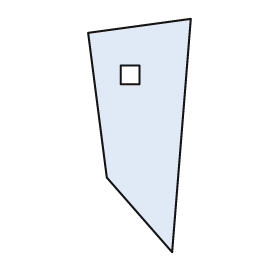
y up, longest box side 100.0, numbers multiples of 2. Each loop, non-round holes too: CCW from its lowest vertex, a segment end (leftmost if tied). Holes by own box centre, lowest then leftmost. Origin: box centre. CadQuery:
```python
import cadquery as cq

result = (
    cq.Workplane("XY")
    .moveTo(14.0, -50.0)
    .lineTo(22.0, 50.0)
    .lineTo(-22.0, 44.0)
    .lineTo(-14.0, -18.0)
    .close()
    .moveTo(-8.0, 22.0)
    .lineTo(0.0, 22.0)
    .lineTo(0.0, 30.0)
    .lineTo(-8.0, 30.0)
    .close()
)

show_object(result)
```